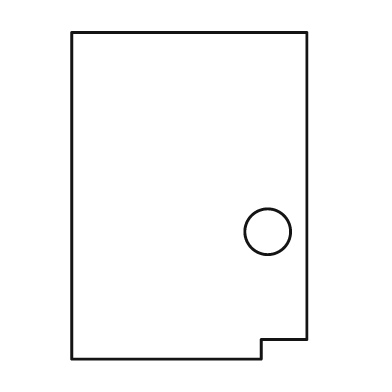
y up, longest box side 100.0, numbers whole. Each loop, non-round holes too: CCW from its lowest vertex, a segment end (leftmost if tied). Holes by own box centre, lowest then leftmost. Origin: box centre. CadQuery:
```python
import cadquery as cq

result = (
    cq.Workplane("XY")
    .moveTo(-36.0, -50.0)
    .lineTo(22.0, -50.0)
    .lineTo(22.0, -44.0)
    .lineTo(36.0, -44.0)
    .lineTo(36.0, 50.0)
    .lineTo(-36.0, 50.0)
    .close()
    .moveTo(24.0, -11.0)
    .circle(7.0)
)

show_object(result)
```